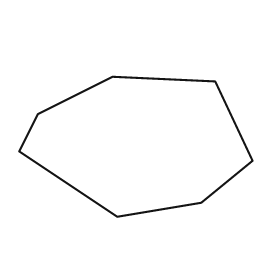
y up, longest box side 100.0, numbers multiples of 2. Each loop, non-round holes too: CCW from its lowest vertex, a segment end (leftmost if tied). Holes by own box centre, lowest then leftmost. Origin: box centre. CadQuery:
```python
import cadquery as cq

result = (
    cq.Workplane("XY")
    .moveTo(-8.0, -30.0)
    .lineTo(28.0, -24.0)
    .lineTo(50.0, -6.0)
    .lineTo(34.0, 28.0)
    .lineTo(-10.0, 30.0)
    .lineTo(-42.0, 14.0)
    .lineTo(-50.0, -2.0)
    .close()
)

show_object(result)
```